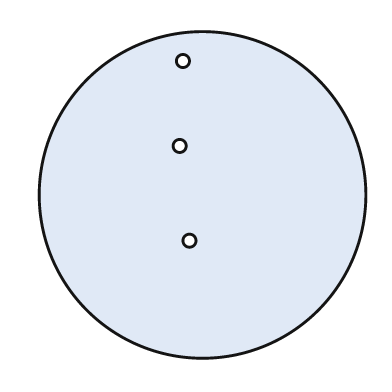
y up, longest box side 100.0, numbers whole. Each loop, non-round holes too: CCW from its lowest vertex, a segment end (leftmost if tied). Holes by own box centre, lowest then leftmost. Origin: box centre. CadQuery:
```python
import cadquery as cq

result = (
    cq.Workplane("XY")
    .moveTo(0.0, 0.0)
    .circle(50.0)
    .moveTo(-4.0, -14.0)
    .circle(2.0)
    .moveTo(-7.0, 15.0)
    .circle(2.0)
    .moveTo(-6.0, 41.0)
    .circle(2.0)
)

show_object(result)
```